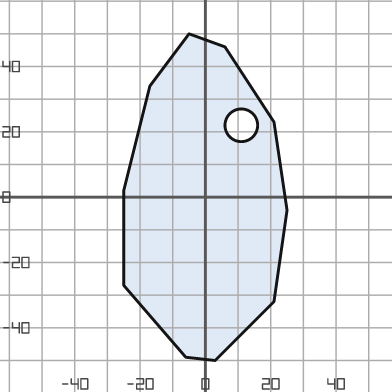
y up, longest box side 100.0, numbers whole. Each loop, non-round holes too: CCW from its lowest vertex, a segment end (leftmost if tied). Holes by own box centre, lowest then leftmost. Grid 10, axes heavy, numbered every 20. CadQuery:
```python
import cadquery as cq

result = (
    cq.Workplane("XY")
    .moveTo(3.0, -50.0)
    .lineTo(21.0, -32.0)
    .lineTo(25.0, -4.0)
    .lineTo(21.0, 23.0)
    .lineTo(6.0, 46.0)
    .lineTo(-5.0, 50.0)
    .lineTo(-17.0, 34.0)
    .lineTo(-25.0, 2.0)
    .lineTo(-25.0, -27.0)
    .lineTo(-6.0, -49.0)
    .close()
    .moveTo(11.0, 22.0)
    .circle(5.0)
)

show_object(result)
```